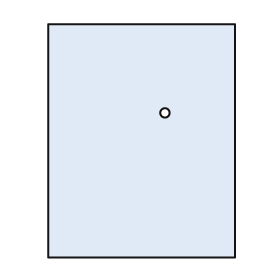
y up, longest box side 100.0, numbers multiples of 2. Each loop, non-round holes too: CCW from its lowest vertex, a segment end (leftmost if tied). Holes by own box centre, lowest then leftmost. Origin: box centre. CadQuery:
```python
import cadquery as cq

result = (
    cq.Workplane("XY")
    .moveTo(-40.0, -50.0)
    .lineTo(40.0, -50.0)
    .lineTo(40.0, 50.0)
    .lineTo(-40.0, 50.0)
    .close()
    .moveTo(10.0, 12.0)
    .circle(2.0)
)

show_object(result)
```